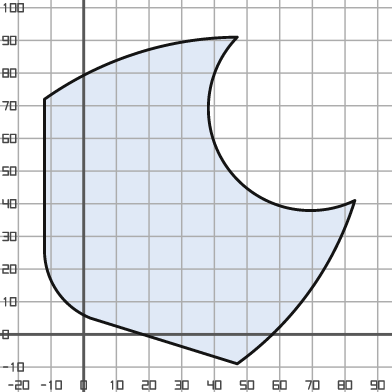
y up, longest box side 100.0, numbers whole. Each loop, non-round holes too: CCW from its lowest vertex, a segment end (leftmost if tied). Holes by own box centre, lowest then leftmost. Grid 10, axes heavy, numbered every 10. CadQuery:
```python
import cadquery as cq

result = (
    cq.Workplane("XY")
    .moveTo(47.0, -9.0)
    .threePointArc((69.0, 13.0), (83.0, 41.0))
    .threePointArc((44.0, 51.0), (47.0, 91.0))
    .threePointArc((16.0, 86.0), (-12.0, 72.0))
    .lineTo(-12.0, 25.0)
    .threePointArc((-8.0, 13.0), (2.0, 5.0))
    .close()
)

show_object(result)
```